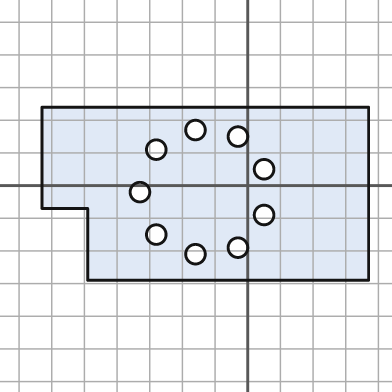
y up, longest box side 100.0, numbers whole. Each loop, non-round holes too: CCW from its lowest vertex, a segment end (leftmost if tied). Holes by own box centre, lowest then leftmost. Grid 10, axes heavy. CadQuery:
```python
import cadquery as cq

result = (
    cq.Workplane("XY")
    .moveTo(-49.0, -29.0)
    .lineTo(37.0, -29.0)
    .lineTo(37.0, 24.0)
    .lineTo(-63.0, 24.0)
    .lineTo(-63.0, -7.0)
    .lineTo(-49.0, -7.0)
    .close()
    .moveTo(-16.0, -21.0)
    .circle(3.0)
    .moveTo(-3.0, -19.0)
    .circle(3.0)
    .moveTo(-28.0, -15.0)
    .circle(3.0)
    .moveTo(5.0, -9.0)
    .circle(3.0)
    .moveTo(-33.0, -2.0)
    .circle(3.0)
    .moveTo(5.0, 5.0)
    .circle(3.0)
    .moveTo(-28.0, 11.0)
    .circle(3.0)
    .moveTo(-3.0, 15.0)
    .circle(3.0)
    .moveTo(-16.0, 17.0)
    .circle(3.0)
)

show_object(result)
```